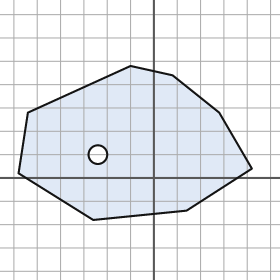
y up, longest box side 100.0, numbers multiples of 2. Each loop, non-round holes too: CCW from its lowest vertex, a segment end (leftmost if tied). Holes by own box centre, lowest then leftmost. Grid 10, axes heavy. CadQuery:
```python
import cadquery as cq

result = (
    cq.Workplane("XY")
    .moveTo(-26.0, -18.0)
    .lineTo(14.0, -14.0)
    .lineTo(42.0, 4.0)
    .lineTo(28.0, 28.0)
    .lineTo(8.0, 44.0)
    .lineTo(-10.0, 48.0)
    .lineTo(-54.0, 28.0)
    .lineTo(-58.0, 2.0)
    .close()
    .moveTo(-24.0, 10.0)
    .circle(4.0)
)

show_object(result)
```